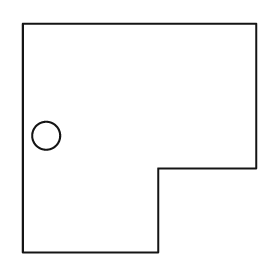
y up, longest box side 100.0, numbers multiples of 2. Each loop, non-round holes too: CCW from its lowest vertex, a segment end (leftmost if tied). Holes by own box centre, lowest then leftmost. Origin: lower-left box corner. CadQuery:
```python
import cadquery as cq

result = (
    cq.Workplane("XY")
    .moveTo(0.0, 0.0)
    .lineTo(58.0, 0.0)
    .lineTo(58.0, 36.0)
    .lineTo(100.0, 36.0)
    .lineTo(100.0, 98.0)
    .lineTo(0.0, 98.0)
    .close()
    .moveTo(10.0, 50.0)
    .circle(6.0)
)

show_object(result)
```